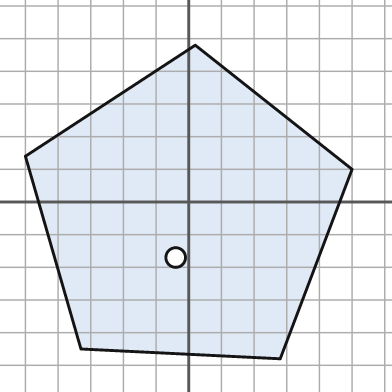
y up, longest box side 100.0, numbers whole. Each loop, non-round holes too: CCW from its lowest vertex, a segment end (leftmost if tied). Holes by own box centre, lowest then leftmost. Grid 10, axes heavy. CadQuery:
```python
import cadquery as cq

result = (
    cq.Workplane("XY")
    .moveTo(28.0, -48.0)
    .lineTo(50.0, 10.0)
    .lineTo(2.0, 48.0)
    .lineTo(-50.0, 14.0)
    .lineTo(-33.0, -45.0)
    .close()
    .moveTo(-4.0, -17.0)
    .circle(3.0)
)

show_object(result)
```